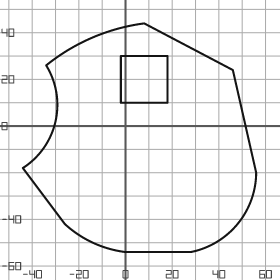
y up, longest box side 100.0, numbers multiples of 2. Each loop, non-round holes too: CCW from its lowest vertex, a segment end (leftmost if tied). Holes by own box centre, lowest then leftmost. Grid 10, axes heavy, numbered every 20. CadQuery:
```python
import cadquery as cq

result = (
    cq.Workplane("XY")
    .moveTo(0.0, -54.0)
    .lineTo(28.0, -54.0)
    .threePointArc((48.0, -42.0), (56.0, -20.0))
    .lineTo(46.0, 24.0)
    .lineTo(8.0, 44.0)
    .threePointArc((-14.0, 38.0), (-34.0, 26.0))
    .threePointArc((-30.0, 2.0), (-44.0, -18.0))
    .lineTo(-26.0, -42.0)
    .threePointArc((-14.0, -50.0), (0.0, -54.0))
    .close()
    .moveTo(-2.0, 10.0)
    .lineTo(18.0, 10.0)
    .lineTo(18.0, 30.0)
    .lineTo(-2.0, 30.0)
    .close()
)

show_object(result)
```